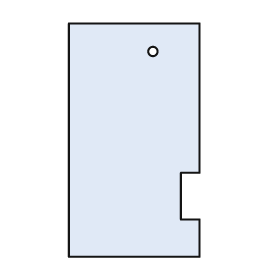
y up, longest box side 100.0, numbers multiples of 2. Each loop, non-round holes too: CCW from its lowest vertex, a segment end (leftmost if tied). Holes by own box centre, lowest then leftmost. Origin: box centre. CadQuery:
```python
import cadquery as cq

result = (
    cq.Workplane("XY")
    .moveTo(-28.0, -50.0)
    .lineTo(28.0, -50.0)
    .lineTo(28.0, -34.0)
    .lineTo(20.0, -34.0)
    .lineTo(20.0, -14.0)
    .lineTo(28.0, -14.0)
    .lineTo(28.0, 50.0)
    .lineTo(-28.0, 50.0)
    .close()
    .moveTo(8.0, 38.0)
    .circle(2.0)
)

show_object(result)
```